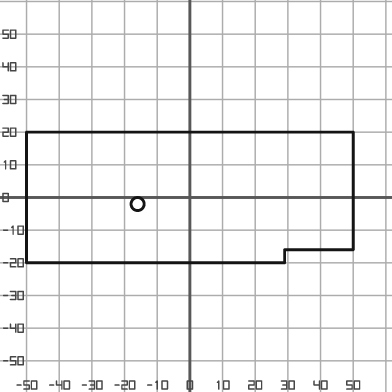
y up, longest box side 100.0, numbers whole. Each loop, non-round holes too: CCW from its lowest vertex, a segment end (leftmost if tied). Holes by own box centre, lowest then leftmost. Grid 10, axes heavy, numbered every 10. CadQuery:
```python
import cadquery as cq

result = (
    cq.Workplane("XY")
    .moveTo(-50.0, -20.0)
    .lineTo(29.0, -20.0)
    .lineTo(29.0, -16.0)
    .lineTo(50.0, -16.0)
    .lineTo(50.0, 20.0)
    .lineTo(-50.0, 20.0)
    .close()
    .moveTo(-16.0, -2.0)
    .circle(2.0)
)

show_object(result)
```